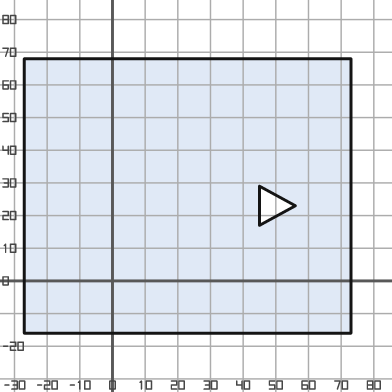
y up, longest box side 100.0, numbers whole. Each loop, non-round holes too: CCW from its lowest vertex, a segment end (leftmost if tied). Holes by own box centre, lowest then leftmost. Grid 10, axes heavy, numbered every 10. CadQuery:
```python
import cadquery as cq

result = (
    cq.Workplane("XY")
    .moveTo(-27.0, -16.0)
    .lineTo(73.0, -16.0)
    .lineTo(73.0, 68.0)
    .lineTo(-27.0, 68.0)
    .close()
    .moveTo(45.0, 17.0)
    .lineTo(56.0, 23.0)
    .lineTo(45.0, 29.0)
    .close()
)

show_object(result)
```